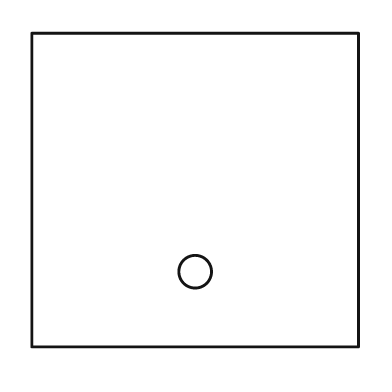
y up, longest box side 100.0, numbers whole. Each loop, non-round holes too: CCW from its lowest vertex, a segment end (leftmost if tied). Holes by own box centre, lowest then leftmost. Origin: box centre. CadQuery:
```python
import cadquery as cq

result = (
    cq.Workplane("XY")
    .moveTo(-50.0, -48.0)
    .lineTo(50.0, -48.0)
    .lineTo(50.0, 48.0)
    .lineTo(-50.0, 48.0)
    .close()
    .moveTo(0.0, -25.0)
    .circle(5.0)
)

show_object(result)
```